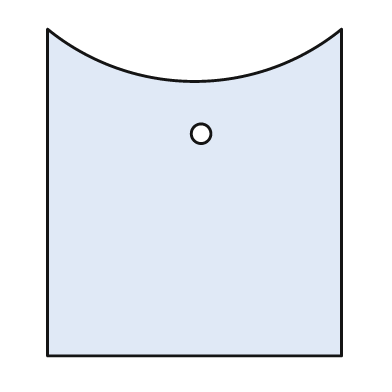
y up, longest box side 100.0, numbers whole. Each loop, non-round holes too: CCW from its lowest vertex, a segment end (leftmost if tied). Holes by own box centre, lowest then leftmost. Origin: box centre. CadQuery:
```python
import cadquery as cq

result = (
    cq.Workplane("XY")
    .moveTo(-45.0, -50.0)
    .lineTo(45.0, -50.0)
    .lineTo(45.0, 50.0)
    .threePointArc((0.0, 34.0), (-45.0, 50.0))
    .close()
    .moveTo(2.0, 18.0)
    .circle(3.0)
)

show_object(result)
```